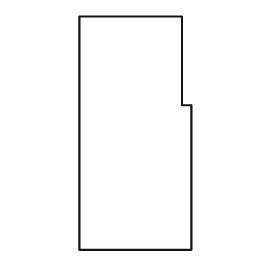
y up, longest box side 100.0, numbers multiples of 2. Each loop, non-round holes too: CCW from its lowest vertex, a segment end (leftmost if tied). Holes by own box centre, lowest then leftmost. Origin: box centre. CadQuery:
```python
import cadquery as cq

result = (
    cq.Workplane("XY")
    .moveTo(-24.0, -50.0)
    .lineTo(24.0, -50.0)
    .lineTo(24.0, 12.0)
    .lineTo(20.0, 12.0)
    .lineTo(20.0, 50.0)
    .lineTo(-24.0, 50.0)
    .close()
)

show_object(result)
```